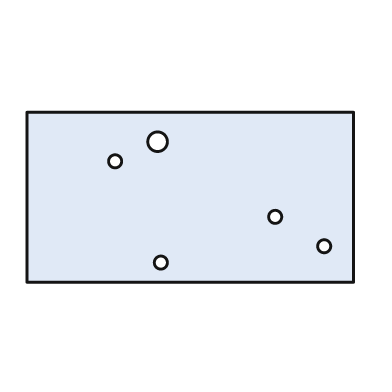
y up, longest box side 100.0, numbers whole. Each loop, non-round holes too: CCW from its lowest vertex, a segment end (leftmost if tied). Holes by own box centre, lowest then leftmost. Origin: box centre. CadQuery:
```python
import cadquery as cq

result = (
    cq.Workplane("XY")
    .moveTo(-50.0, -26.0)
    .lineTo(50.0, -26.0)
    .lineTo(50.0, 26.0)
    .lineTo(-50.0, 26.0)
    .close()
    .moveTo(-9.0, -20.0)
    .circle(2.0)
    .moveTo(41.0, -15.0)
    .circle(2.0)
    .moveTo(26.0, -6.0)
    .circle(2.0)
    .moveTo(-23.0, 11.0)
    .circle(2.0)
    .moveTo(-10.0, 17.0)
    .circle(3.0)
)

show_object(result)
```